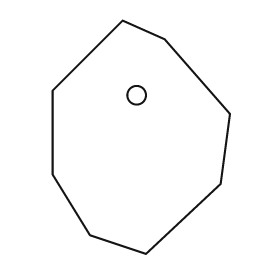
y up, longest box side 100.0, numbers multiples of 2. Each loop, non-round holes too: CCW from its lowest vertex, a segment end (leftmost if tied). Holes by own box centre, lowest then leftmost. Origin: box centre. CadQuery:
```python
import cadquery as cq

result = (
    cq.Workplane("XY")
    .moveTo(2.0, -50.0)
    .lineTo(34.0, -20.0)
    .lineTo(38.0, 10.0)
    .lineTo(10.0, 42.0)
    .lineTo(-8.0, 50.0)
    .lineTo(-38.0, 20.0)
    .lineTo(-38.0, -16.0)
    .lineTo(-22.0, -42.0)
    .close()
    .moveTo(-2.0, 18.0)
    .circle(4.0)
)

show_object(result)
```